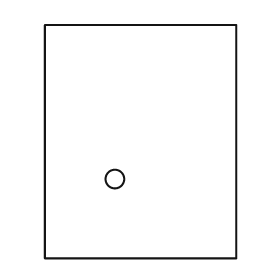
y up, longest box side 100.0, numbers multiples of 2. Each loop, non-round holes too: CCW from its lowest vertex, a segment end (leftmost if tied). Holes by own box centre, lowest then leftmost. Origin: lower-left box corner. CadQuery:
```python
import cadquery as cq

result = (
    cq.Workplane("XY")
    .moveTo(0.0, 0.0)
    .lineTo(82.0, 0.0)
    .lineTo(82.0, 100.0)
    .lineTo(0.0, 100.0)
    .close()
    .moveTo(30.0, 34.0)
    .circle(4.0)
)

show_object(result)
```